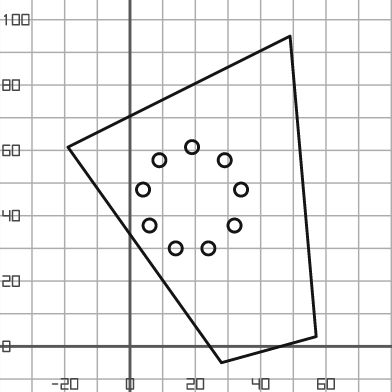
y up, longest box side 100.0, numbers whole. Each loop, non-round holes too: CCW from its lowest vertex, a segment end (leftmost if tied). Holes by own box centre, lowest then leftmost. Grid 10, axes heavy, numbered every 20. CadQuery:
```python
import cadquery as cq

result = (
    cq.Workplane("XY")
    .moveTo(28.0, -5.0)
    .lineTo(57.0, 3.0)
    .lineTo(49.0, 95.0)
    .lineTo(-19.0, 61.0)
    .close()
    .moveTo(14.0, 30.0)
    .circle(2.0)
    .moveTo(24.0, 30.0)
    .circle(2.0)
    .moveTo(6.0, 37.0)
    .circle(2.0)
    .moveTo(32.0, 37.0)
    .circle(2.0)
    .moveTo(4.0, 48.0)
    .circle(2.0)
    .moveTo(34.0, 48.0)
    .circle(2.0)
    .moveTo(9.0, 57.0)
    .circle(2.0)
    .moveTo(29.0, 57.0)
    .circle(2.0)
    .moveTo(19.0, 61.0)
    .circle(2.0)
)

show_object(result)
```